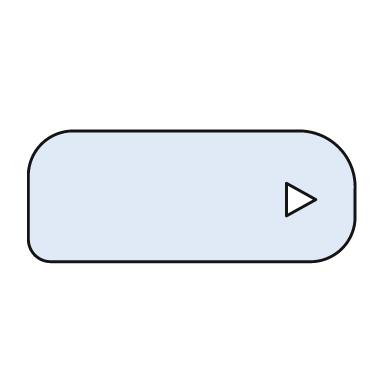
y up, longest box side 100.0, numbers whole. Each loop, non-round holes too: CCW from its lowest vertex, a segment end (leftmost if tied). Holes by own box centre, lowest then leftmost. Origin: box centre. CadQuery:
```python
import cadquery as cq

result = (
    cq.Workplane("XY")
    .moveTo(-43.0, -20.0)
    .lineTo(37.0, -20.0)
    .threePointArc((46.0, -16.0), (50.0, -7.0))
    .lineTo(50.0, 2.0)
    .threePointArc((45.0, 15.0), (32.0, 20.0))
    .lineTo(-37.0, 20.0)
    .threePointArc((-46.0, 16.0), (-50.0, 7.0))
    .lineTo(-50.0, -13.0)
    .threePointArc((-48.0, -18.0), (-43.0, -20.0))
    .close()
    .moveTo(29.0, -6.0)
    .lineTo(38.0, -1.0)
    .lineTo(29.0, 4.0)
    .close()
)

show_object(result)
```